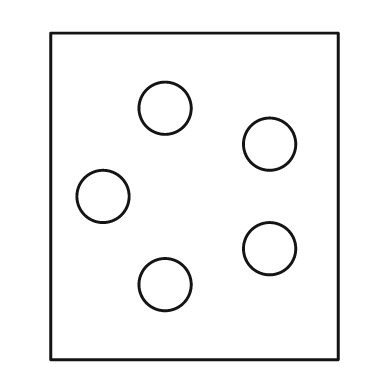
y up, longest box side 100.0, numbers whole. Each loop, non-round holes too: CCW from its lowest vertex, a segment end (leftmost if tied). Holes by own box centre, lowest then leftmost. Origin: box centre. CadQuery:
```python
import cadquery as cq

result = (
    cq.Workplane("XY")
    .moveTo(-44.0, -50.0)
    .lineTo(44.0, -50.0)
    .lineTo(44.0, 50.0)
    .lineTo(-44.0, 50.0)
    .close()
    .moveTo(-9.0, -27.0)
    .circle(8.0)
    .moveTo(23.0, -16.0)
    .circle(8.0)
    .moveTo(-28.0, 0.0)
    .circle(8.0)
    .moveTo(23.0, 16.0)
    .circle(8.0)
    .moveTo(-9.0, 27.0)
    .circle(8.0)
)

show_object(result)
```